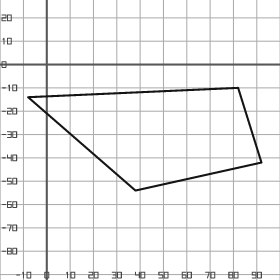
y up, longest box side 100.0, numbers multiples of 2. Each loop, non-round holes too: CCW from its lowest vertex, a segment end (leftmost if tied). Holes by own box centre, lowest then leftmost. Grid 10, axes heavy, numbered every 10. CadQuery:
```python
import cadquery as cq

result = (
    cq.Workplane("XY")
    .moveTo(38.0, -54.0)
    .lineTo(92.0, -42.0)
    .lineTo(82.0, -10.0)
    .lineTo(-8.0, -14.0)
    .close()
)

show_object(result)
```